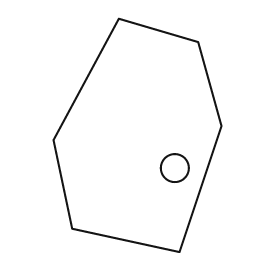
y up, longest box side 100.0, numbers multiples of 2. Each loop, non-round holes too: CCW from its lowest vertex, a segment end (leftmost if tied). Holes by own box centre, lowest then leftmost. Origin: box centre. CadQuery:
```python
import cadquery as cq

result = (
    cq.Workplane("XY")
    .moveTo(18.0, -50.0)
    .lineTo(36.0, 4.0)
    .lineTo(26.0, 40.0)
    .lineTo(-8.0, 50.0)
    .lineTo(-36.0, -2.0)
    .lineTo(-28.0, -40.0)
    .close()
    .moveTo(16.0, -14.0)
    .circle(6.0)
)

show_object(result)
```